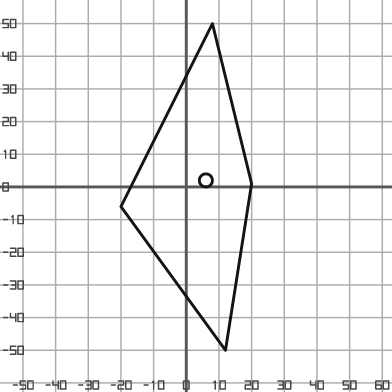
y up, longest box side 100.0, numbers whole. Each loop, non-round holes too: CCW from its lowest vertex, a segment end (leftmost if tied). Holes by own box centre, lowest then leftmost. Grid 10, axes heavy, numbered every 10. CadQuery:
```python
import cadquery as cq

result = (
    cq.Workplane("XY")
    .moveTo(12.0, -50.0)
    .lineTo(20.0, 1.0)
    .lineTo(8.0, 50.0)
    .lineTo(-20.0, -6.0)
    .close()
    .moveTo(6.0, 2.0)
    .circle(2.0)
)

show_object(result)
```